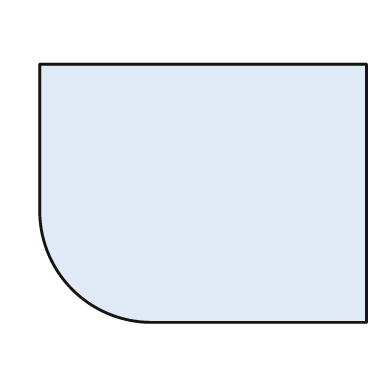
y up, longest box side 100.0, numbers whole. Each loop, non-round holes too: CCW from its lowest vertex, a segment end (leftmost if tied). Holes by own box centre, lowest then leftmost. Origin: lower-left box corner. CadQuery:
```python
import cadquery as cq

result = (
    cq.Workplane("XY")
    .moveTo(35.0, 0.0)
    .lineTo(100.0, 0.0)
    .lineTo(100.0, 79.0)
    .lineTo(0.0, 79.0)
    .lineTo(0.0, 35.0)
    .threePointArc((10.0, 10.0), (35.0, 0.0))
    .close()
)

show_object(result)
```